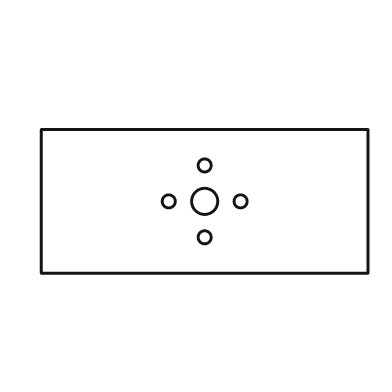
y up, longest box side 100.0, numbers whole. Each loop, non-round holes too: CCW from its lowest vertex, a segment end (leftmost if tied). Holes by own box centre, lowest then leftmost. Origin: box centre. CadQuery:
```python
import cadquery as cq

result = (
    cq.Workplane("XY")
    .moveTo(-50.0, -22.0)
    .lineTo(50.0, -22.0)
    .lineTo(50.0, 22.0)
    .lineTo(-50.0, 22.0)
    .close()
    .moveTo(0.0, -11.0)
    .circle(2.0)
    .moveTo(-11.0, 0.0)
    .circle(2.0)
    .moveTo(0.0, 0.0)
    .circle(4.0)
    .moveTo(11.0, 0.0)
    .circle(2.0)
    .moveTo(0.0, 11.0)
    .circle(2.0)
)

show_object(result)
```